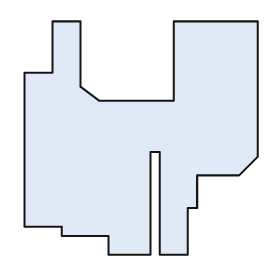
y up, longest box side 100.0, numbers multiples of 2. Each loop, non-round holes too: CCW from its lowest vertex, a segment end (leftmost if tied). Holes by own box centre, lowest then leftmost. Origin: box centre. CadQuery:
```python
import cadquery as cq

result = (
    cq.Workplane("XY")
    .moveTo(-14.0, -50.0)
    .lineTo(4.0, -50.0)
    .lineTo(4.0, -6.0)
    .lineTo(8.0, -6.0)
    .lineTo(8.0, -50.0)
    .lineTo(20.0, -50.0)
    .lineTo(20.0, -30.0)
    .lineTo(24.0, -30.0)
    .lineTo(24.0, -16.0)
    .lineTo(42.0, -16.0)
    .lineTo(50.0, -8.0)
    .lineTo(50.0, 50.0)
    .lineTo(14.0, 50.0)
    .lineTo(14.0, 16.0)
    .lineTo(-18.0, 16.0)
    .lineTo(-26.0, 22.0)
    .lineTo(-26.0, 50.0)
    .lineTo(-38.0, 50.0)
    .lineTo(-38.0, 28.0)
    .lineTo(-50.0, 28.0)
    .lineTo(-50.0, -38.0)
    .lineTo(-34.0, -38.0)
    .lineTo(-34.0, -42.0)
    .lineTo(-14.0, -42.0)
    .close()
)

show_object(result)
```